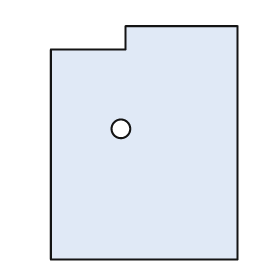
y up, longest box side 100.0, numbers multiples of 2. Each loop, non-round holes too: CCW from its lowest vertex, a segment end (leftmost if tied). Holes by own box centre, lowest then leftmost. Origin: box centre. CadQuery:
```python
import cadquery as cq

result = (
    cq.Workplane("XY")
    .moveTo(-40.0, -50.0)
    .lineTo(40.0, -50.0)
    .lineTo(40.0, 50.0)
    .lineTo(-8.0, 50.0)
    .lineTo(-8.0, 40.0)
    .lineTo(-40.0, 40.0)
    .close()
    .moveTo(-10.0, 6.0)
    .circle(4.0)
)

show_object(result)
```